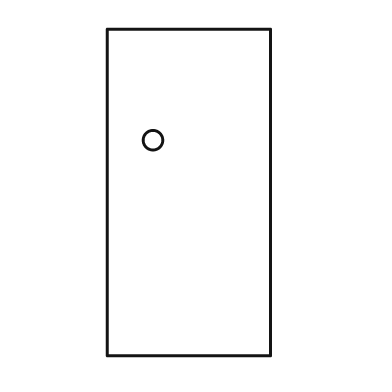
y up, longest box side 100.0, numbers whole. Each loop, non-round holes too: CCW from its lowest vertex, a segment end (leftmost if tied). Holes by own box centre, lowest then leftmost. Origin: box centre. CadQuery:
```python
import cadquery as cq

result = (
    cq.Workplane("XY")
    .moveTo(-25.0, -50.0)
    .lineTo(25.0, -50.0)
    .lineTo(25.0, 50.0)
    .lineTo(-25.0, 50.0)
    .close()
    .moveTo(-11.0, 16.0)
    .circle(3.0)
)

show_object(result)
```